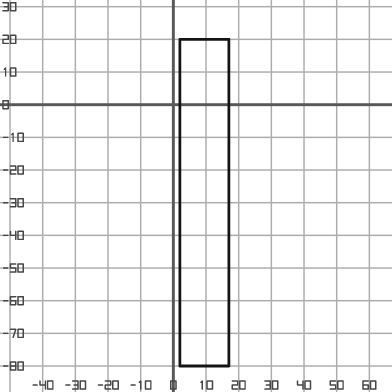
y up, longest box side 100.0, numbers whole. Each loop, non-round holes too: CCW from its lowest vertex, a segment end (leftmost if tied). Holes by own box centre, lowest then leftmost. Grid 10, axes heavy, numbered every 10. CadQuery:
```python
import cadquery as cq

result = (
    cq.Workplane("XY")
    .moveTo(2.0, -80.0)
    .lineTo(17.0, -80.0)
    .lineTo(17.0, 20.0)
    .lineTo(2.0, 20.0)
    .close()
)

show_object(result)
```